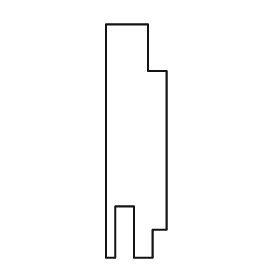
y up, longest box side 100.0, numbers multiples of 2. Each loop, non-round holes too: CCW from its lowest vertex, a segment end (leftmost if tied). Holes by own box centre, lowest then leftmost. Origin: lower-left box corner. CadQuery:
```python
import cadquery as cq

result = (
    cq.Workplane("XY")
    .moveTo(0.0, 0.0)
    .lineTo(4.0, 0.0)
    .lineTo(4.0, 22.0)
    .lineTo(12.0, 22.0)
    .lineTo(12.0, 0.0)
    .lineTo(20.0, 0.0)
    .lineTo(20.0, 12.0)
    .lineTo(26.0, 12.0)
    .lineTo(26.0, 80.0)
    .lineTo(18.0, 80.0)
    .lineTo(18.0, 100.0)
    .lineTo(0.0, 100.0)
    .close()
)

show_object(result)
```